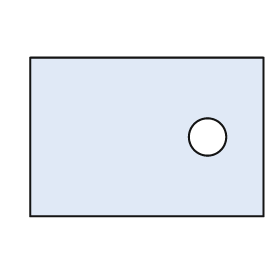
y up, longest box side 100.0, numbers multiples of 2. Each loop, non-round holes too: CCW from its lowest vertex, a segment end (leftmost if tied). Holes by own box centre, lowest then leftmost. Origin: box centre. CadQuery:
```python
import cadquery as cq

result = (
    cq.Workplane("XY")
    .moveTo(-50.0, -34.0)
    .lineTo(50.0, -34.0)
    .lineTo(50.0, 34.0)
    .lineTo(-50.0, 34.0)
    .close()
    .moveTo(26.0, 0.0)
    .circle(8.0)
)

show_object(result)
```